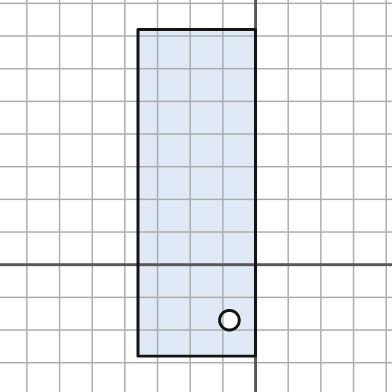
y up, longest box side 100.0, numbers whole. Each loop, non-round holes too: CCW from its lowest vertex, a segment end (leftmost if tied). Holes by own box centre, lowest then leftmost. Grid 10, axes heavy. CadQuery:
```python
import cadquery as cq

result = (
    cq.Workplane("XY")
    .moveTo(-36.0, -28.0)
    .lineTo(0.0, -28.0)
    .lineTo(0.0, 72.0)
    .lineTo(-36.0, 72.0)
    .close()
    .moveTo(-8.0, -17.0)
    .circle(3.0)
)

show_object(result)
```